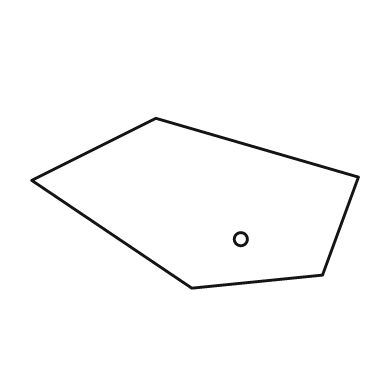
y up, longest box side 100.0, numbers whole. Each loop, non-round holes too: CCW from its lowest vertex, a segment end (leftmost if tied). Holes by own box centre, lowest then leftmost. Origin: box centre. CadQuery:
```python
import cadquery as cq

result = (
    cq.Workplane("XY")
    .moveTo(-1.0, -26.0)
    .lineTo(39.0, -22.0)
    .lineTo(50.0, 8.0)
    .lineTo(-12.0, 26.0)
    .lineTo(-50.0, 7.0)
    .close()
    .moveTo(14.0, -11.0)
    .circle(2.0)
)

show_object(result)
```